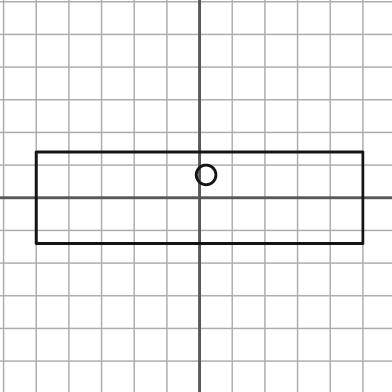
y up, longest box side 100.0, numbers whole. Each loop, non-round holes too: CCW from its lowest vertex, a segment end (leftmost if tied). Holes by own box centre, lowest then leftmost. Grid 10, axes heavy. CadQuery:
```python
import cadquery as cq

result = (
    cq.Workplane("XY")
    .moveTo(-50.0, -14.0)
    .lineTo(50.0, -14.0)
    .lineTo(50.0, 14.0)
    .lineTo(-50.0, 14.0)
    .close()
    .moveTo(2.0, 7.0)
    .circle(3.0)
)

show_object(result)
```